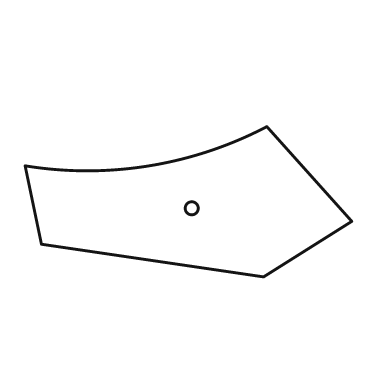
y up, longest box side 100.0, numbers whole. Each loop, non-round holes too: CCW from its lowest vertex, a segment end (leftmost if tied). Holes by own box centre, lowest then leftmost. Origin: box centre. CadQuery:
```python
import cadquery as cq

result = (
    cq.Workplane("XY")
    .moveTo(23.0, -23.0)
    .lineTo(50.0, -6.0)
    .lineTo(24.0, 23.0)
    .threePointArc((-12.0, 11.0), (-50.0, 11.0))
    .lineTo(-45.0, -13.0)
    .close()
    .moveTo(1.0, -2.0)
    .circle(2.0)
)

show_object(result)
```